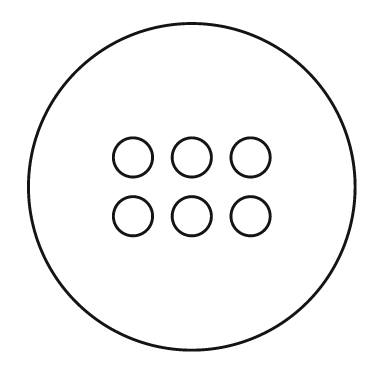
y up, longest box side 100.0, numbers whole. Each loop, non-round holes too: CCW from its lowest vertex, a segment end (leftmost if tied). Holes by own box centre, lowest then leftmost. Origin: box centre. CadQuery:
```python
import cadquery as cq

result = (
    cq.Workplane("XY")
    .moveTo(0.0, 0.0)
    .circle(50.0)
    .moveTo(-18.0, -9.0)
    .circle(6.0)
    .moveTo(0.0, -9.0)
    .circle(6.0)
    .moveTo(18.0, -9.0)
    .circle(6.0)
    .moveTo(-18.0, 9.0)
    .circle(6.0)
    .moveTo(0.0, 9.0)
    .circle(6.0)
    .moveTo(18.0, 9.0)
    .circle(6.0)
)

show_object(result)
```